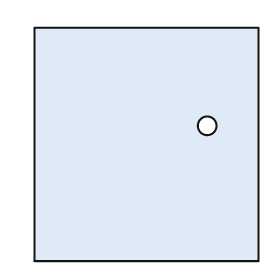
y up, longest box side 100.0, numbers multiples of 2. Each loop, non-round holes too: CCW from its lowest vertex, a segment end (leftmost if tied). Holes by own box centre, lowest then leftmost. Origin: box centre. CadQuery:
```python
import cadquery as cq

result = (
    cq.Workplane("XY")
    .moveTo(-48.0, -50.0)
    .lineTo(48.0, -50.0)
    .lineTo(48.0, 50.0)
    .lineTo(-48.0, 50.0)
    .close()
    .moveTo(26.0, 8.0)
    .circle(4.0)
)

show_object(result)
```